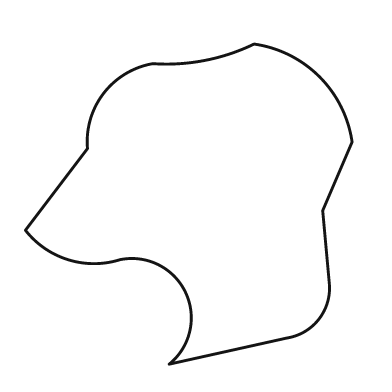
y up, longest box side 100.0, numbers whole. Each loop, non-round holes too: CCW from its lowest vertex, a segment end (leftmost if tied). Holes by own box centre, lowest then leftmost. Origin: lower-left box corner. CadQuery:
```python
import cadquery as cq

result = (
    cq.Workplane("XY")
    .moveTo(44.0, 0.0)
    .lineTo(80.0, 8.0)
    .threePointArc((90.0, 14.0), (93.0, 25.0))
    .lineTo(91.0, 47.0)
    .lineTo(100.0, 68.0)
    .threePointArc((90.0, 88.0), (70.0, 98.0))
    .threePointArc((55.0, 93.0), (39.0, 92.0))
    .threePointArc((24.0, 83.0), (19.0, 66.0))
    .lineTo(0.0, 41.0)
    .threePointArc((13.0, 32.0), (29.0, 32.0))
    .threePointArc((49.0, 22.0), (44.0, 0.0))
    .close()
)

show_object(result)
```